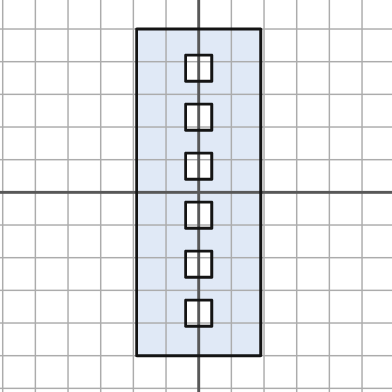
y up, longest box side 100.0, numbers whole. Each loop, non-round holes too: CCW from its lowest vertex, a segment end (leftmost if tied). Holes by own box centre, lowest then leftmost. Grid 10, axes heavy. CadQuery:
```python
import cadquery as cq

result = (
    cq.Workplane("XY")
    .moveTo(-19.0, -50.0)
    .lineTo(19.0, -50.0)
    .lineTo(19.0, 50.0)
    .lineTo(-19.0, 50.0)
    .close()
    .moveTo(-4.0, -41.0)
    .lineTo(4.0, -41.0)
    .lineTo(4.0, -33.0)
    .lineTo(-4.0, -33.0)
    .close()
    .moveTo(-4.0, -26.0)
    .lineTo(4.0, -26.0)
    .lineTo(4.0, -18.0)
    .lineTo(-4.0, -18.0)
    .close()
    .moveTo(-4.0, -11.0)
    .lineTo(4.0, -11.0)
    .lineTo(4.0, -3.0)
    .lineTo(-4.0, -3.0)
    .close()
    .moveTo(-4.0, 4.0)
    .lineTo(4.0, 4.0)
    .lineTo(4.0, 12.0)
    .lineTo(-4.0, 12.0)
    .close()
    .moveTo(-4.0, 19.0)
    .lineTo(4.0, 19.0)
    .lineTo(4.0, 27.0)
    .lineTo(-4.0, 27.0)
    .close()
    .moveTo(-4.0, 34.0)
    .lineTo(4.0, 34.0)
    .lineTo(4.0, 42.0)
    .lineTo(-4.0, 42.0)
    .close()
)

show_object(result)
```